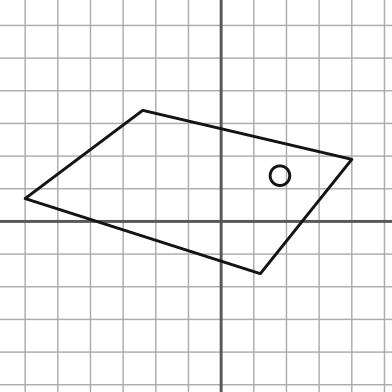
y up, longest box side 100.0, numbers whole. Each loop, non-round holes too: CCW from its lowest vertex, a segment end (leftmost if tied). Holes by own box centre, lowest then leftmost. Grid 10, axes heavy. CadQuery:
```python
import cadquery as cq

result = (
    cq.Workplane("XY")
    .moveTo(12.0, -16.0)
    .lineTo(40.0, 19.0)
    .lineTo(-24.0, 34.0)
    .lineTo(-60.0, 7.0)
    .close()
    .moveTo(18.0, 14.0)
    .circle(3.0)
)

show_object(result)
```